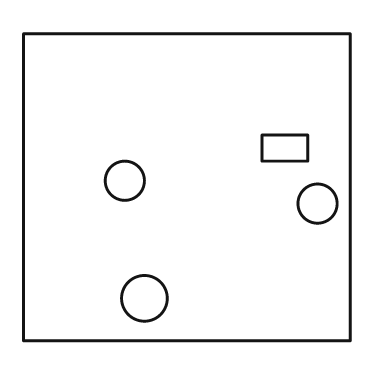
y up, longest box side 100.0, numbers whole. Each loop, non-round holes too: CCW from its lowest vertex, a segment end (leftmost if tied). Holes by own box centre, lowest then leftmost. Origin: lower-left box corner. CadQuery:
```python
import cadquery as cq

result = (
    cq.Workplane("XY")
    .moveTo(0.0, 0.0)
    .lineTo(100.0, 0.0)
    .lineTo(100.0, 94.0)
    .lineTo(0.0, 94.0)
    .close()
    .moveTo(37.0, 13.0)
    .circle(7.0)
    .moveTo(90.0, 42.0)
    .circle(6.0)
    .moveTo(31.0, 49.0)
    .circle(6.0)
    .moveTo(73.0, 55.0)
    .lineTo(87.0, 55.0)
    .lineTo(87.0, 63.0)
    .lineTo(73.0, 63.0)
    .close()
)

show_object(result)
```